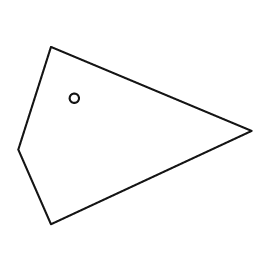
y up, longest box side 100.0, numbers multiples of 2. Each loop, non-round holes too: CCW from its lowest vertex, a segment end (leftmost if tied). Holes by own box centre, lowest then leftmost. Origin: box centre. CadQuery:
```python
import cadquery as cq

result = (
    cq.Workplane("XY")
    .moveTo(-36.0, -38.0)
    .lineTo(50.0, 2.0)
    .lineTo(-36.0, 38.0)
    .lineTo(-50.0, -6.0)
    .close()
    .moveTo(-26.0, 16.0)
    .circle(2.0)
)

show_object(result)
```